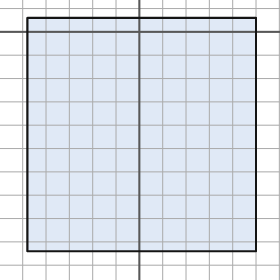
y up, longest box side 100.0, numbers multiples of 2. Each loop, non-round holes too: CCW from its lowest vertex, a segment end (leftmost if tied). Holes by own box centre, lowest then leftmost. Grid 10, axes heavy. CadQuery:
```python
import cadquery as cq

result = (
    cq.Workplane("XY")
    .moveTo(-48.0, -94.0)
    .lineTo(50.0, -94.0)
    .lineTo(50.0, 6.0)
    .lineTo(-48.0, 6.0)
    .close()
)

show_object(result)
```